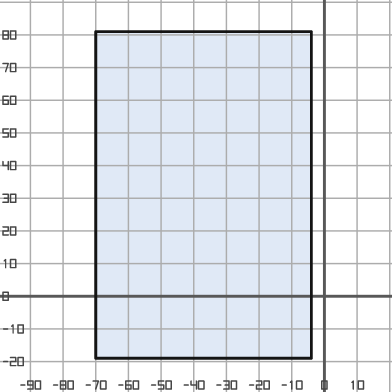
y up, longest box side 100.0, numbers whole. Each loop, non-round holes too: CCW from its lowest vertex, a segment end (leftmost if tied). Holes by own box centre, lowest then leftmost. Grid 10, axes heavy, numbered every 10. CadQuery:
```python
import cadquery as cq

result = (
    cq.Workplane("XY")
    .moveTo(-70.0, -19.0)
    .lineTo(-4.0, -19.0)
    .lineTo(-4.0, 81.0)
    .lineTo(-70.0, 81.0)
    .close()
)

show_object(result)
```